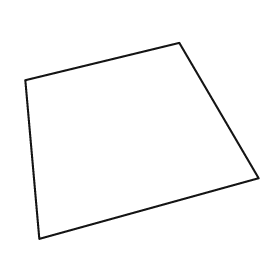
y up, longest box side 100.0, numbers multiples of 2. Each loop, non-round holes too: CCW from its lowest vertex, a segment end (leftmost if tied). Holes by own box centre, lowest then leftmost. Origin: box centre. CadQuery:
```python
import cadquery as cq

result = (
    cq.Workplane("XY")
    .moveTo(-44.0, -42.0)
    .lineTo(50.0, -16.0)
    .lineTo(16.0, 42.0)
    .lineTo(-50.0, 26.0)
    .close()
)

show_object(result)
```